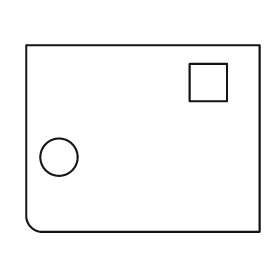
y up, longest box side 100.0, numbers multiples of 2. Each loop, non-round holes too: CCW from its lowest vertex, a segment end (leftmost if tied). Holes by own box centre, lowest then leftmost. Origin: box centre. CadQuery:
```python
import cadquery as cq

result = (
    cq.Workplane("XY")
    .moveTo(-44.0, -40.0)
    .lineTo(50.0, -40.0)
    .lineTo(50.0, 40.0)
    .lineTo(-50.0, 40.0)
    .lineTo(-50.0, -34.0)
    .threePointArc((-48.0, -38.0), (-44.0, -40.0))
    .close()
    .moveTo(-36.0, -8.0)
    .circle(8.0)
    .moveTo(20.0, 16.0)
    .lineTo(36.0, 16.0)
    .lineTo(36.0, 32.0)
    .lineTo(20.0, 32.0)
    .close()
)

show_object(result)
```